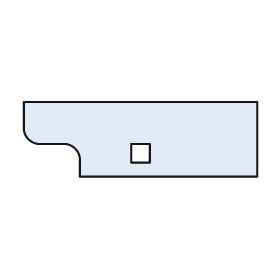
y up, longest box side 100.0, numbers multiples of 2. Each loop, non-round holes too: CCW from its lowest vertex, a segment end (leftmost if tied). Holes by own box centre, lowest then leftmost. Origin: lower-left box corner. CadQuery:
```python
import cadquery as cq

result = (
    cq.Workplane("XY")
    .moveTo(24.0, 0.0)
    .lineTo(100.0, 0.0)
    .lineTo(100.0, 32.0)
    .lineTo(0.0, 32.0)
    .lineTo(0.0, 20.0)
    .threePointArc((2.0, 16.0), (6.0, 14.0))
    .lineTo(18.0, 14.0)
    .threePointArc((22.0, 12.0), (24.0, 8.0))
    .close()
    .moveTo(46.0, 6.0)
    .lineTo(54.0, 6.0)
    .lineTo(54.0, 14.0)
    .lineTo(46.0, 14.0)
    .close()
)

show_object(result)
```